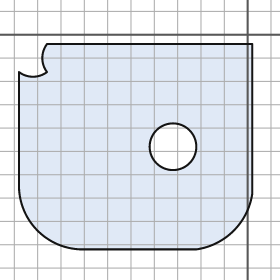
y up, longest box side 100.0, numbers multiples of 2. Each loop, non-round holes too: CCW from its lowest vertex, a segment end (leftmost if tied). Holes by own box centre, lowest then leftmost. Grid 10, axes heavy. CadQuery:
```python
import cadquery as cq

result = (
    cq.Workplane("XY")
    .moveTo(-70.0, -92.0)
    .lineTo(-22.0, -92.0)
    .threePointArc((-6.0, -84.0), (2.0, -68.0))
    .lineTo(2.0, -4.0)
    .lineTo(-86.0, -4.0)
    .threePointArc((-88.0, -10.0), (-86.0, -16.0))
    .threePointArc((-92.0, -18.0), (-98.0, -16.0))
    .lineTo(-98.0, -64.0)
    .threePointArc((-90.0, -84.0), (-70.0, -92.0))
    .close()
    .moveTo(-32.0, -48.0)
    .circle(10.0)
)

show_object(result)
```